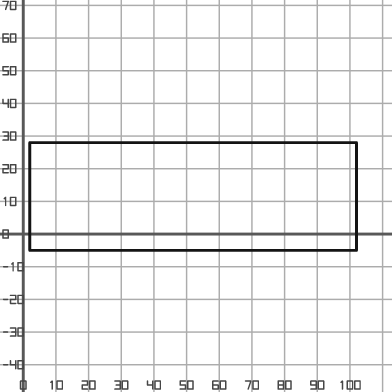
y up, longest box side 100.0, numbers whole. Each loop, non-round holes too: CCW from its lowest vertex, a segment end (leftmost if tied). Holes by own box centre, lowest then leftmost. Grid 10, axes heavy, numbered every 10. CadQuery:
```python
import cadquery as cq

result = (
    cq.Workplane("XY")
    .moveTo(2.0, -5.0)
    .lineTo(102.0, -5.0)
    .lineTo(102.0, 28.0)
    .lineTo(2.0, 28.0)
    .close()
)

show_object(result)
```